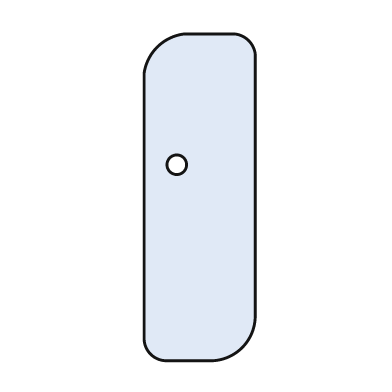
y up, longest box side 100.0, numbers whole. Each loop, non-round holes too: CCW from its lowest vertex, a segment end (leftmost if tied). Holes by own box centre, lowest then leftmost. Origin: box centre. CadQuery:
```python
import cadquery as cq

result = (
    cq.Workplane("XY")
    .moveTo(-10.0, -50.0)
    .lineTo(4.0, -50.0)
    .threePointArc((13.0, -46.0), (17.0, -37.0))
    .lineTo(17.0, 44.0)
    .threePointArc((15.0, 48.0), (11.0, 50.0))
    .lineTo(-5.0, 50.0)
    .threePointArc((-13.0, 46.0), (-17.0, 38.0))
    .lineTo(-17.0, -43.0)
    .threePointArc((-15.0, -48.0), (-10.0, -50.0))
    .close()
    .moveTo(-7.0, 10.0)
    .circle(3.0)
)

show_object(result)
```